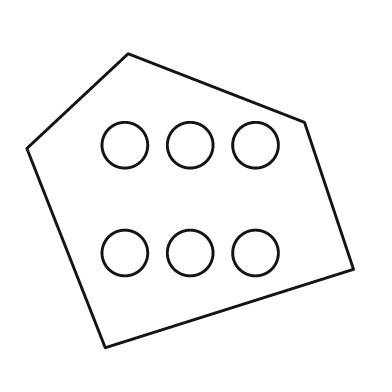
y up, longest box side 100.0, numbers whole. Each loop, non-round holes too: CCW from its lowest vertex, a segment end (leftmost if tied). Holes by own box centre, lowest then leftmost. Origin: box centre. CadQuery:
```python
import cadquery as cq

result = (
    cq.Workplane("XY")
    .moveTo(-26.0, -45.0)
    .lineTo(50.0, -21.0)
    .lineTo(35.0, 24.0)
    .lineTo(-19.0, 45.0)
    .lineTo(-50.0, 16.0)
    .close()
    .moveTo(-20.0, -16.0)
    .circle(7.0)
    .moveTo(0.0, -16.0)
    .circle(7.0)
    .moveTo(20.0, -16.0)
    .circle(7.0)
    .moveTo(-20.0, 17.0)
    .circle(7.0)
    .moveTo(0.0, 17.0)
    .circle(7.0)
    .moveTo(20.0, 17.0)
    .circle(7.0)
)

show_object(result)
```